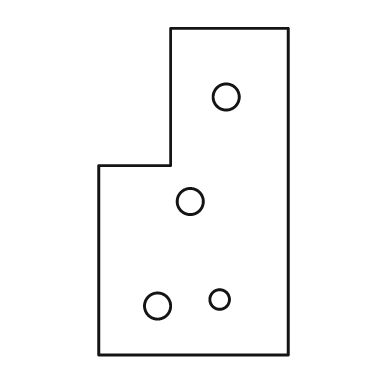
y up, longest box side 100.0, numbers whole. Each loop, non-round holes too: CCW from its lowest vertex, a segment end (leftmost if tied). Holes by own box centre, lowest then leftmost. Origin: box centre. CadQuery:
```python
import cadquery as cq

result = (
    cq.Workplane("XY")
    .moveTo(-29.0, -50.0)
    .lineTo(29.0, -50.0)
    .lineTo(29.0, 50.0)
    .lineTo(-7.0, 50.0)
    .lineTo(-7.0, 8.0)
    .lineTo(-29.0, 8.0)
    .close()
    .moveTo(-11.0, -35.0)
    .circle(4.0)
    .moveTo(8.0, -33.0)
    .circle(3.0)
    .moveTo(-1.0, -3.0)
    .circle(4.0)
    .moveTo(10.0, 29.0)
    .circle(4.0)
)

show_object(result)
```